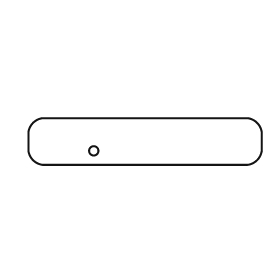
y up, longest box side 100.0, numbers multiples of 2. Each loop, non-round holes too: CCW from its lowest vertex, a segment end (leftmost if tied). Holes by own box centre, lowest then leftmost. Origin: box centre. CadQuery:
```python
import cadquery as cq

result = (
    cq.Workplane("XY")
    .moveTo(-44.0, -10.0)
    .lineTo(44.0, -10.0)
    .threePointArc((48.0, -8.0), (50.0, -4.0))
    .lineTo(50.0, 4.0)
    .threePointArc((48.0, 8.0), (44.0, 10.0))
    .lineTo(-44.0, 10.0)
    .threePointArc((-48.0, 8.0), (-50.0, 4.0))
    .lineTo(-50.0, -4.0)
    .threePointArc((-48.0, -8.0), (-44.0, -10.0))
    .close()
    .moveTo(-22.0, -4.0)
    .circle(2.0)
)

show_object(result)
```